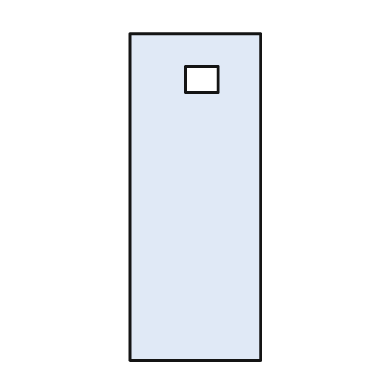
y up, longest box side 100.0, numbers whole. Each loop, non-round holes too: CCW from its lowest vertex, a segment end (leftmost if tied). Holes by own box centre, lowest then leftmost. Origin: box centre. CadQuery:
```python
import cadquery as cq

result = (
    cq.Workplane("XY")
    .moveTo(-20.0, -50.0)
    .lineTo(20.0, -50.0)
    .lineTo(20.0, 50.0)
    .lineTo(-20.0, 50.0)
    .close()
    .moveTo(-3.0, 32.0)
    .lineTo(7.0, 32.0)
    .lineTo(7.0, 40.0)
    .lineTo(-3.0, 40.0)
    .close()
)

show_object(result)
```